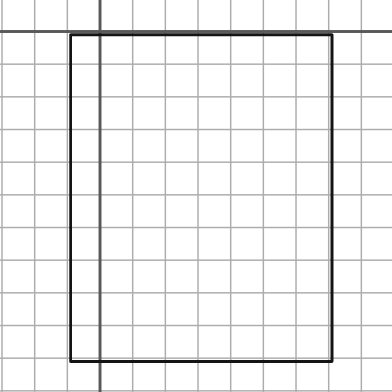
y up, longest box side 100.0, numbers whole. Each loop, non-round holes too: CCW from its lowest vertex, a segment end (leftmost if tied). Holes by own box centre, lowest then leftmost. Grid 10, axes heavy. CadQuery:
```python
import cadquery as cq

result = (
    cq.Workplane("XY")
    .moveTo(-9.0, -101.0)
    .lineTo(71.0, -101.0)
    .lineTo(71.0, -1.0)
    .lineTo(-9.0, -1.0)
    .close()
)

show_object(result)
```